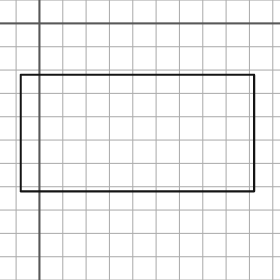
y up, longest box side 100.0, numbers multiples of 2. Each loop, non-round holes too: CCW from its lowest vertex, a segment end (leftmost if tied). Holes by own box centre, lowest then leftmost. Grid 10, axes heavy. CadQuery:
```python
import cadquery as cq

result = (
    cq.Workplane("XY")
    .moveTo(-8.0, -72.0)
    .lineTo(92.0, -72.0)
    .lineTo(92.0, -22.0)
    .lineTo(-8.0, -22.0)
    .close()
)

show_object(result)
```